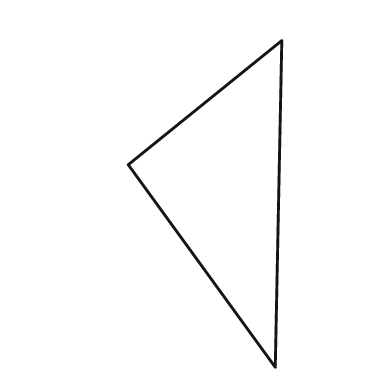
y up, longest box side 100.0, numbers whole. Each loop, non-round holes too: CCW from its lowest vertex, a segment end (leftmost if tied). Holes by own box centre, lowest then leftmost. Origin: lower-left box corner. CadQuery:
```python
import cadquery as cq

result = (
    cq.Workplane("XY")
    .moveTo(45.0, 0.0)
    .lineTo(47.0, 100.0)
    .lineTo(0.0, 62.0)
    .close()
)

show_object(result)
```